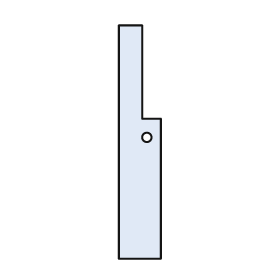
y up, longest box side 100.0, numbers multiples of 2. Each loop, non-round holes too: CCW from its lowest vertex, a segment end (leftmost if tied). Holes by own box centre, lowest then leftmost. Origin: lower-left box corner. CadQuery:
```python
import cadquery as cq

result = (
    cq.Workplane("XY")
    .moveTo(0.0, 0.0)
    .lineTo(18.0, 0.0)
    .lineTo(18.0, 60.0)
    .lineTo(10.0, 60.0)
    .lineTo(10.0, 100.0)
    .lineTo(0.0, 100.0)
    .close()
    .moveTo(12.0, 52.0)
    .circle(2.0)
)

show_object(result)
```